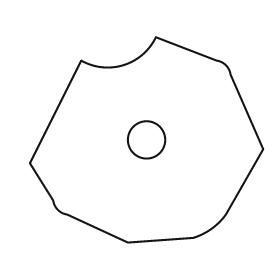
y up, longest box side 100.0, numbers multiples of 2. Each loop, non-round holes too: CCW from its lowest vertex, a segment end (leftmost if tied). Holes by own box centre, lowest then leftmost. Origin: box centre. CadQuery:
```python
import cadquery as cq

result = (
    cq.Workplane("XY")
    .moveTo(-8.0, -44.0)
    .lineTo(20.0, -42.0)
    .threePointArc((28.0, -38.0), (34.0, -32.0))
    .lineTo(50.0, -4.0)
    .lineTo(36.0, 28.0)
    .threePointArc((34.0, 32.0), (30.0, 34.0))
    .lineTo(4.0, 44.0)
    .threePointArc((-10.0, 32.0), (-28.0, 34.0))
    .lineTo(-50.0, -10.0)
    .lineTo(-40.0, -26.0)
    .threePointArc((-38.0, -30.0), (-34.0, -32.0))
    .close()
    .moveTo(0.0, 0.0)
    .circle(8.0)
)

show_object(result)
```